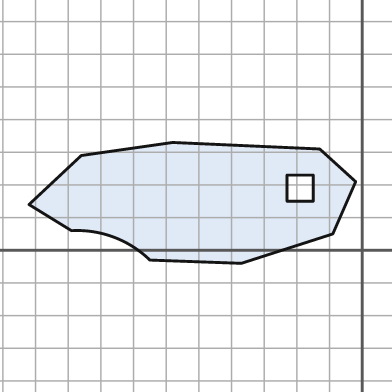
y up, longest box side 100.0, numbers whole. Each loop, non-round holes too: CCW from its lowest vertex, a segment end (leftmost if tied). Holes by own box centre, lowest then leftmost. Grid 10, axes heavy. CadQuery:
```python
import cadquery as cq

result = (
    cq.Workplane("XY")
    .moveTo(-37.0, -4.0)
    .lineTo(-9.0, 5.0)
    .lineTo(-2.0, 21.0)
    .lineTo(-13.0, 31.0)
    .lineTo(-58.0, 33.0)
    .lineTo(-86.0, 29.0)
    .lineTo(-102.0, 14.0)
    .lineTo(-89.0, 6.0)
    .threePointArc((-76.0, 4.0), (-65.0, -3.0))
    .close()
    .moveTo(-23.0, 15.0)
    .lineTo(-15.0, 15.0)
    .lineTo(-15.0, 23.0)
    .lineTo(-23.0, 23.0)
    .close()
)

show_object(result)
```